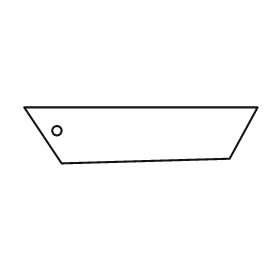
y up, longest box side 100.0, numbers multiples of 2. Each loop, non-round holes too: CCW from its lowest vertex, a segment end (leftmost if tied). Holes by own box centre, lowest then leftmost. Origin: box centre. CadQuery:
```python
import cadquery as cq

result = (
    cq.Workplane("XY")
    .moveTo(-34.0, -12.0)
    .lineTo(38.0, -10.0)
    .lineTo(50.0, 12.0)
    .lineTo(-50.0, 12.0)
    .close()
    .moveTo(-36.0, 2.0)
    .circle(2.0)
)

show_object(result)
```